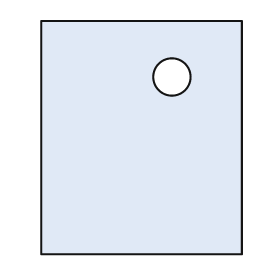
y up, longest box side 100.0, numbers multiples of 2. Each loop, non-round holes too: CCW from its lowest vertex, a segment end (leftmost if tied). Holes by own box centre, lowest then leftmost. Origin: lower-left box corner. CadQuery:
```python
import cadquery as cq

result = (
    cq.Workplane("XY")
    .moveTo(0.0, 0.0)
    .lineTo(86.0, 0.0)
    .lineTo(86.0, 100.0)
    .lineTo(0.0, 100.0)
    .close()
    .moveTo(56.0, 76.0)
    .circle(8.0)
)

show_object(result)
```